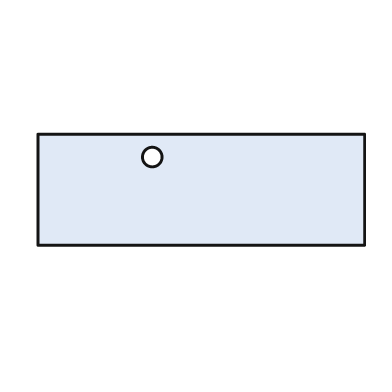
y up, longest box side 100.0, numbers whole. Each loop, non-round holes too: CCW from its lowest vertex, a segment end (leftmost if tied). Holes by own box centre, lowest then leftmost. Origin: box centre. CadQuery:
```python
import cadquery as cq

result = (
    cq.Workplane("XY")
    .moveTo(-50.0, -17.0)
    .lineTo(50.0, -17.0)
    .lineTo(50.0, 17.0)
    .lineTo(-50.0, 17.0)
    .close()
    .moveTo(-15.0, 10.0)
    .circle(3.0)
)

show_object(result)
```